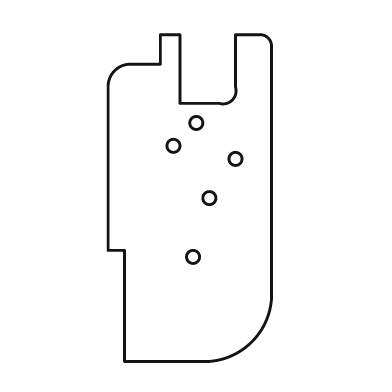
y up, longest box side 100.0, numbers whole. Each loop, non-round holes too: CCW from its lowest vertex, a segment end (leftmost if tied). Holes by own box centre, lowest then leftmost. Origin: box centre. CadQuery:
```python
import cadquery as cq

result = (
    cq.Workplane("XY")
    .moveTo(-20.0, -50.0)
    .lineTo(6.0, -50.0)
    .threePointArc((19.0, -44.0), (25.0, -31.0))
    .lineTo(25.0, 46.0)
    .threePointArc((24.0, 49.0), (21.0, 50.0))
    .lineTo(14.0, 50.0)
    .lineTo(14.0, 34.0)
    .threePointArc((13.0, 30.0), (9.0, 29.0))
    .lineTo(-3.0, 29.0)
    .lineTo(-3.0, 50.0)
    .lineTo(-9.0, 50.0)
    .lineTo(-9.0, 41.0)
    .lineTo(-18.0, 41.0)
    .threePointArc((-23.0, 39.0), (-25.0, 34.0))
    .lineTo(-25.0, -16.0)
    .lineTo(-20.0, -16.0)
    .close()
    .moveTo(1.0, -18.0)
    .circle(2.0)
    .moveTo(6.0, 0.0)
    .circle(2.0)
    .moveTo(14.0, 12.0)
    .circle(2.0)
    .moveTo(-5.0, 16.0)
    .circle(2.0)
    .moveTo(2.0, 23.0)
    .circle(2.0)
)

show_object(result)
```